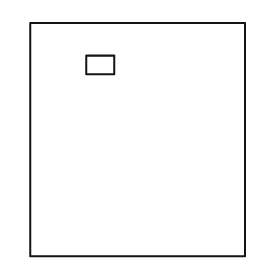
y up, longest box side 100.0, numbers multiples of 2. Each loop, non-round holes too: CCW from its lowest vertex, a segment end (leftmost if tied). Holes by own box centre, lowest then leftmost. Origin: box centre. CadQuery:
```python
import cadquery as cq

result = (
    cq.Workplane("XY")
    .moveTo(-46.0, -50.0)
    .lineTo(46.0, -50.0)
    .lineTo(46.0, 50.0)
    .lineTo(-46.0, 50.0)
    .close()
    .moveTo(-22.0, 28.0)
    .lineTo(-10.0, 28.0)
    .lineTo(-10.0, 36.0)
    .lineTo(-22.0, 36.0)
    .close()
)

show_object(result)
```